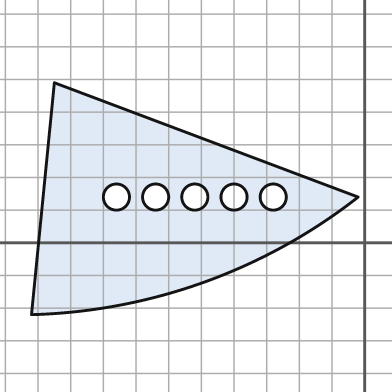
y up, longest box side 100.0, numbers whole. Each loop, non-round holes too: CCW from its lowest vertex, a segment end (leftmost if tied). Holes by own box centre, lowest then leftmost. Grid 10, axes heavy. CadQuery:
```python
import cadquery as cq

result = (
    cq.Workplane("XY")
    .moveTo(-102.0, -22.0)
    .threePointArc((-49.0, -12.0), (-2.0, 14.0))
    .lineTo(-95.0, 49.0)
    .close()
    .moveTo(-76.0, 14.0)
    .circle(4.0)
    .moveTo(-64.0, 14.0)
    .circle(4.0)
    .moveTo(-52.0, 14.0)
    .circle(4.0)
    .moveTo(-40.0, 14.0)
    .circle(4.0)
    .moveTo(-28.0, 14.0)
    .circle(4.0)
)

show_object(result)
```